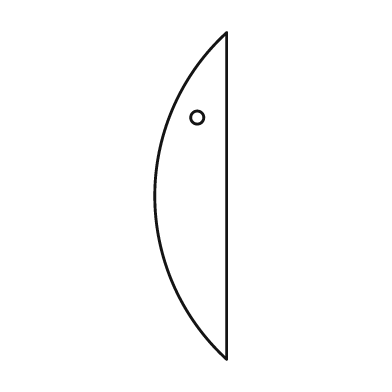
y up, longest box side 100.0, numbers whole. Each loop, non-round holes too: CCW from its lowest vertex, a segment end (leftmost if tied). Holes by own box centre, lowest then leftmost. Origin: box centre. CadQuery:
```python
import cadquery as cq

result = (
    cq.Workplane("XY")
    .moveTo(11.0, -50.0)
    .lineTo(11.0, 50.0)
    .threePointArc((-11.0, 0.0), (11.0, -50.0))
    .close()
    .moveTo(2.0, 24.0)
    .circle(2.0)
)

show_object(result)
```